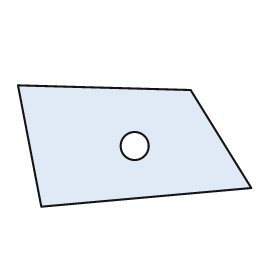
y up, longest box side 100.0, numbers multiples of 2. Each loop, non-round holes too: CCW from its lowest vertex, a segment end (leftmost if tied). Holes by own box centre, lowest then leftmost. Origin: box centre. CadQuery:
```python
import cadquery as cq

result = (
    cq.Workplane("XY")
    .moveTo(-40.0, -26.0)
    .lineTo(50.0, -18.0)
    .lineTo(24.0, 24.0)
    .lineTo(-50.0, 26.0)
    .close()
    .moveTo(0.0, 0.0)
    .circle(6.0)
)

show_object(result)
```